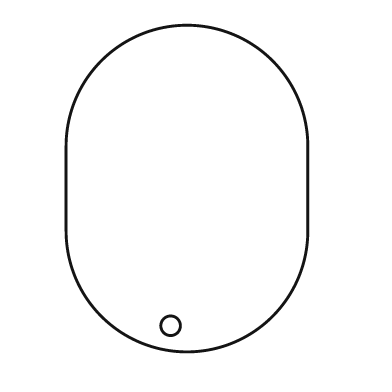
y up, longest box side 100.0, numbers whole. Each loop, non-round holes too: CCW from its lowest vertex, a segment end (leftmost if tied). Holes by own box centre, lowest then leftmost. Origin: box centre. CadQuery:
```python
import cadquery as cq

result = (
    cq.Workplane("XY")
    .moveTo(-37.0, -13.0)
    .threePointArc((0.0, -50.0), (37.0, -13.0))
    .lineTo(37.0, 13.0)
    .threePointArc((0.0, 50.0), (-37.0, 13.0))
    .close()
    .moveTo(-5.0, -42.0)
    .circle(3.0)
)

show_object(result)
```